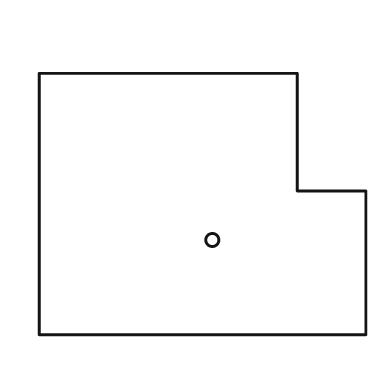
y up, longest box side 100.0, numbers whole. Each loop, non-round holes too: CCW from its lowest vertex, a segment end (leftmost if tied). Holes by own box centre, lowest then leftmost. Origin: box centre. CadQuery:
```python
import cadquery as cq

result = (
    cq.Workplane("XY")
    .moveTo(-50.0, -40.0)
    .lineTo(50.0, -40.0)
    .lineTo(50.0, 4.0)
    .lineTo(29.0, 4.0)
    .lineTo(29.0, 40.0)
    .lineTo(-50.0, 40.0)
    .close()
    .moveTo(3.0, -11.0)
    .circle(2.0)
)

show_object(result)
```